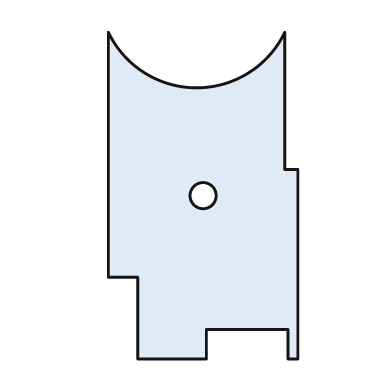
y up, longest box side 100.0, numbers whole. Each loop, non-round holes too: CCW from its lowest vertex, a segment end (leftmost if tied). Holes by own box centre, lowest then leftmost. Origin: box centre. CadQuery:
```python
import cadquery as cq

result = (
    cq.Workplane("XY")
    .moveTo(-20.0, -50.0)
    .lineTo(1.0, -50.0)
    .lineTo(1.0, -41.0)
    .lineTo(26.0, -41.0)
    .lineTo(26.0, -50.0)
    .lineTo(29.0, -50.0)
    .lineTo(29.0, 8.0)
    .lineTo(25.0, 8.0)
    .lineTo(25.0, 50.0)
    .threePointArc((-2.0, 33.0), (-29.0, 50.0))
    .lineTo(-29.0, -25.0)
    .lineTo(-20.0, -25.0)
    .close()
    .moveTo(0.0, 0.0)
    .circle(4.0)
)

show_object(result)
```